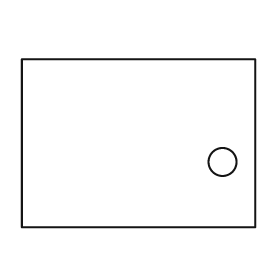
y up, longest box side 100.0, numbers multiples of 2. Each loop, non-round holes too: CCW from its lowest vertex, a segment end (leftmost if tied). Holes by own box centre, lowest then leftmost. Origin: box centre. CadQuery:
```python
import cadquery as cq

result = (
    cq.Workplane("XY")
    .moveTo(-50.0, -36.0)
    .lineTo(50.0, -36.0)
    .lineTo(50.0, 36.0)
    .lineTo(-50.0, 36.0)
    .close()
    .moveTo(36.0, -8.0)
    .circle(6.0)
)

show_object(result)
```